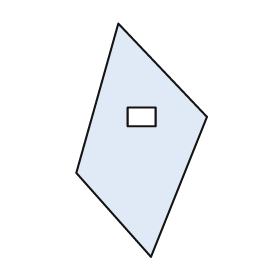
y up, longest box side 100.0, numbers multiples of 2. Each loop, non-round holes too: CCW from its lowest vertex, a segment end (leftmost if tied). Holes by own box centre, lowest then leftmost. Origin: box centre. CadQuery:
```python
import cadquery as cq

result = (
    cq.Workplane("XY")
    .moveTo(4.0, -50.0)
    .lineTo(28.0, 10.0)
    .lineTo(-10.0, 50.0)
    .lineTo(-28.0, -14.0)
    .close()
    .moveTo(-6.0, 6.0)
    .lineTo(6.0, 6.0)
    .lineTo(6.0, 14.0)
    .lineTo(-6.0, 14.0)
    .close()
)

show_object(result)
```